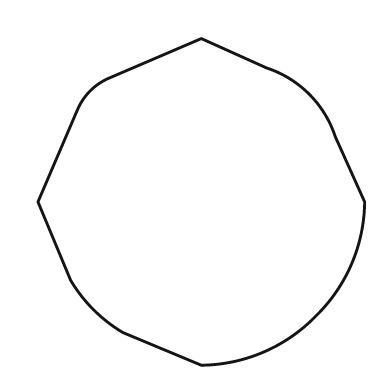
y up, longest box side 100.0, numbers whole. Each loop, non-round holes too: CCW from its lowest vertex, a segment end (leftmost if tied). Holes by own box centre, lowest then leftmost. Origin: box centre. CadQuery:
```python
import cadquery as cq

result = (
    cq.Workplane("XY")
    .moveTo(0.0, -50.0)
    .threePointArc((19.0, -46.0), (35.0, -35.0))
    .threePointArc((46.0, -19.0), (50.0, 0.0))
    .lineTo(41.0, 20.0)
    .threePointArc((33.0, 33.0), (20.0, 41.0))
    .lineTo(0.0, 50.0)
    .lineTo(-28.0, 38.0)
    .threePointArc((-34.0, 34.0), (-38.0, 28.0))
    .lineTo(-50.0, 0.0)
    .lineTo(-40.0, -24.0)
    .threePointArc((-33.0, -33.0), (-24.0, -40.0))
    .close()
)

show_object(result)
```